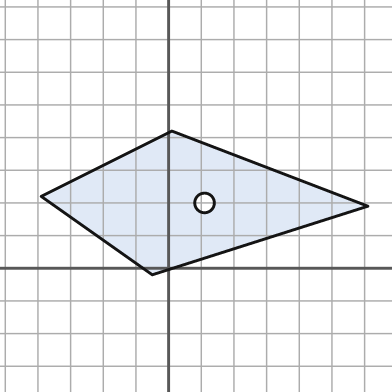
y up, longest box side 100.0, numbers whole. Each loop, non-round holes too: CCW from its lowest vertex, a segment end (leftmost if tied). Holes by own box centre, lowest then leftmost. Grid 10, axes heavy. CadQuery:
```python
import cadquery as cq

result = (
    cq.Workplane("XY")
    .moveTo(-5.0, -2.0)
    .lineTo(61.0, 19.0)
    .lineTo(1.0, 42.0)
    .lineTo(-39.0, 22.0)
    .close()
    .moveTo(11.0, 20.0)
    .circle(3.0)
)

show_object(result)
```